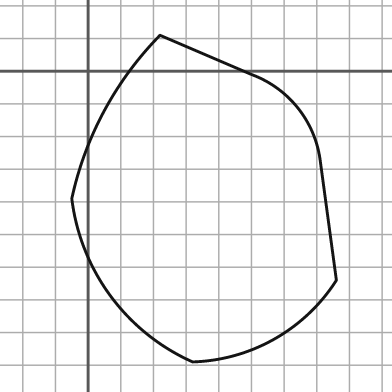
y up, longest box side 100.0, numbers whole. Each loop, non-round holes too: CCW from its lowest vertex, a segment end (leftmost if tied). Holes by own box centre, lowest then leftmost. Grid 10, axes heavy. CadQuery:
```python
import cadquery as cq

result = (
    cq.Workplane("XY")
    .moveTo(32.0, -89.0)
    .threePointArc((57.0, -82.0), (76.0, -64.0))
    .lineTo(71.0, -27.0)
    .threePointArc((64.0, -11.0), (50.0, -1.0))
    .lineTo(22.0, 11.0)
    .threePointArc((5.0, -12.0), (-5.0, -39.0))
    .threePointArc((7.0, -69.0), (32.0, -89.0))
    .close()
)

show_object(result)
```